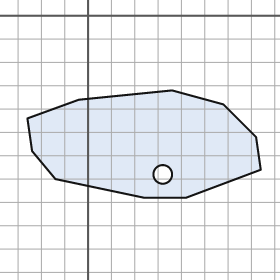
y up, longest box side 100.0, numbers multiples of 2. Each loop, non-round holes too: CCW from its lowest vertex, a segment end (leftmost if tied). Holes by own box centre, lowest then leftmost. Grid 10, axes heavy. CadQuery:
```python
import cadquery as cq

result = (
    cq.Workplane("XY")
    .moveTo(24.0, -78.0)
    .lineTo(42.0, -78.0)
    .lineTo(74.0, -66.0)
    .lineTo(72.0, -52.0)
    .lineTo(58.0, -38.0)
    .lineTo(36.0, -32.0)
    .lineTo(-4.0, -36.0)
    .lineTo(-26.0, -44.0)
    .lineTo(-24.0, -58.0)
    .lineTo(-14.0, -70.0)
    .close()
    .moveTo(32.0, -68.0)
    .circle(4.0)
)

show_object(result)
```